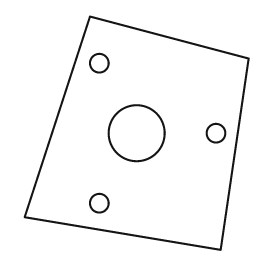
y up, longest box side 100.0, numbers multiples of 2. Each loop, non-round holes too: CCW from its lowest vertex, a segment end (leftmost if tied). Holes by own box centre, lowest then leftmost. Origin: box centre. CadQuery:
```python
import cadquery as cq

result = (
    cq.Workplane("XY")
    .moveTo(36.0, -50.0)
    .lineTo(48.0, 32.0)
    .lineTo(-20.0, 50.0)
    .lineTo(-48.0, -36.0)
    .close()
    .moveTo(-16.0, -30.0)
    .circle(4.0)
    .moveTo(0.0, 0.0)
    .circle(12.0)
    .moveTo(34.0, 0.0)
    .circle(4.0)
    .moveTo(-16.0, 30.0)
    .circle(4.0)
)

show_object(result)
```